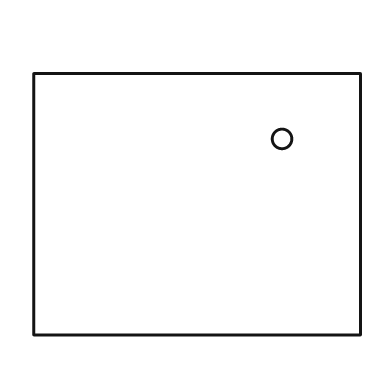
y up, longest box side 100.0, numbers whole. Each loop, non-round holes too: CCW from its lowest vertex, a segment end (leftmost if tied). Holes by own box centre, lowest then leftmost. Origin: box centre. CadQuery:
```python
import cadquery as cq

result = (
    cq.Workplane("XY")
    .moveTo(-50.0, -40.0)
    .lineTo(50.0, -40.0)
    .lineTo(50.0, 40.0)
    .lineTo(-50.0, 40.0)
    .close()
    .moveTo(26.0, 20.0)
    .circle(3.0)
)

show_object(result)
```